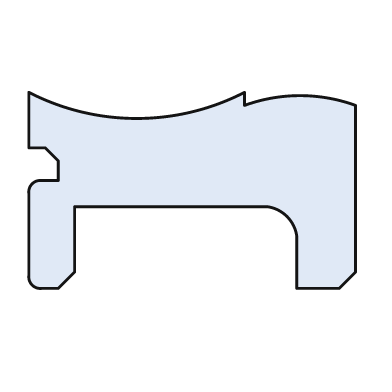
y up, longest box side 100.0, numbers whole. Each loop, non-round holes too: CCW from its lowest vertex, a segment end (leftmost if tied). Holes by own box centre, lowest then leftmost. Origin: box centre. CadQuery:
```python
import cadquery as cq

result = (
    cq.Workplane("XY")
    .moveTo(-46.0, -30.0)
    .lineTo(-41.0, -30.0)
    .lineTo(-36.0, -25.0)
    .lineTo(-36.0, -5.0)
    .lineTo(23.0, -5.0)
    .threePointArc((29.0, -8.0), (32.0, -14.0))
    .lineTo(32.0, -30.0)
    .lineTo(45.0, -30.0)
    .lineTo(50.0, -25.0)
    .lineTo(50.0, 26.0)
    .threePointArc((33.0, 29.0), (16.0, 26.0))
    .lineTo(16.0, 30.0)
    .threePointArc((-17.0, 22.0), (-50.0, 30.0))
    .lineTo(-50.0, 13.0)
    .lineTo(-45.0, 13.0)
    .lineTo(-41.0, 9.0)
    .lineTo(-41.0, 3.0)
    .lineTo(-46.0, 3.0)
    .threePointArc((-49.0, 2.0), (-50.0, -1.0))
    .lineTo(-50.0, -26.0)
    .threePointArc((-49.0, -29.0), (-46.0, -30.0))
    .close()
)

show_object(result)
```